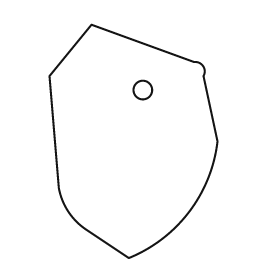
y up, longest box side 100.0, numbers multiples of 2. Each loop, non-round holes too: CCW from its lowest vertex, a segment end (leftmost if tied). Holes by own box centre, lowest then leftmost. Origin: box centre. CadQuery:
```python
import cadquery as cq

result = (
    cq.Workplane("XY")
    .moveTo(-2.0, -50.0)
    .threePointArc((24.0, -30.0), (36.0, 0.0))
    .lineTo(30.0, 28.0)
    .threePointArc((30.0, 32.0), (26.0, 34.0))
    .lineTo(-18.0, 50.0)
    .lineTo(-36.0, 28.0)
    .lineTo(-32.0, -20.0)
    .threePointArc((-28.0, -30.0), (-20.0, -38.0))
    .close()
    .moveTo(4.0, 22.0)
    .circle(4.0)
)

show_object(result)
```